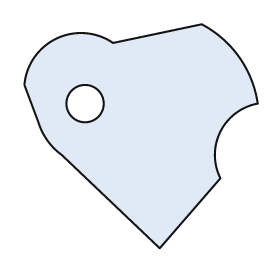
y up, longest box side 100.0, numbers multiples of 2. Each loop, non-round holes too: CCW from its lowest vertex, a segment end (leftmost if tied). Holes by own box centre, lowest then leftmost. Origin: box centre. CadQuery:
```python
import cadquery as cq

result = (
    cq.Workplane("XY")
    .moveTo(8.0, -48.0)
    .lineTo(34.0, -18.0)
    .threePointArc((34.0, 2.0), (50.0, 14.0))
    .threePointArc((42.0, 34.0), (26.0, 48.0))
    .lineTo(-12.0, 40.0)
    .threePointArc((-36.0, 42.0), (-50.0, 22.0))
    .lineTo(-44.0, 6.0)
    .threePointArc((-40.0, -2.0), (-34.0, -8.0))
    .close()
    .moveTo(-24.0, 14.0)
    .circle(8.0)
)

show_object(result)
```